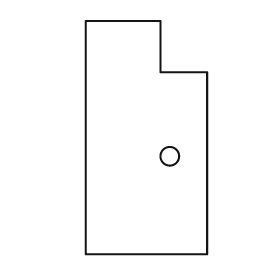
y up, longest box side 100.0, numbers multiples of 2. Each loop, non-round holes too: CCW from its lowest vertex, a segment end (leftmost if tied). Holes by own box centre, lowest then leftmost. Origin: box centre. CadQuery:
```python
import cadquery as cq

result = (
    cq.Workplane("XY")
    .moveTo(-26.0, -50.0)
    .lineTo(26.0, -50.0)
    .lineTo(26.0, 28.0)
    .lineTo(6.0, 28.0)
    .lineTo(6.0, 50.0)
    .lineTo(-26.0, 50.0)
    .close()
    .moveTo(10.0, -8.0)
    .circle(4.0)
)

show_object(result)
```